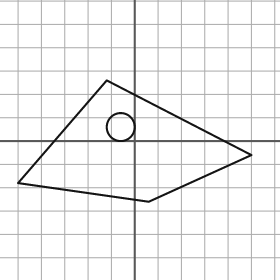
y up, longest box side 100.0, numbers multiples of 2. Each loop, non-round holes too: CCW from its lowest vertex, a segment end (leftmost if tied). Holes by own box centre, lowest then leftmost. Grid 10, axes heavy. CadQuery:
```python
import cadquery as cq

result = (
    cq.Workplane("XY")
    .moveTo(6.0, -26.0)
    .lineTo(50.0, -6.0)
    .lineTo(-12.0, 26.0)
    .lineTo(-50.0, -18.0)
    .close()
    .moveTo(-6.0, 6.0)
    .circle(6.0)
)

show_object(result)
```